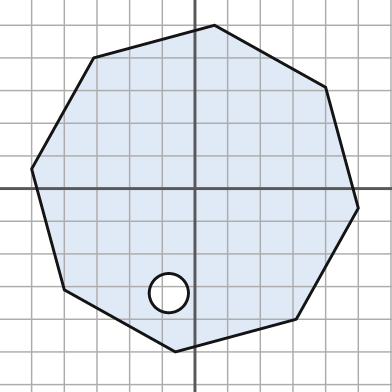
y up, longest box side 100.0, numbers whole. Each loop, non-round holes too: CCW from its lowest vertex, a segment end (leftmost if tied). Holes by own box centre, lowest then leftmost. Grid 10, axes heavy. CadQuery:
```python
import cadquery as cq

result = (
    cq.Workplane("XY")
    .moveTo(-6.0, -50.0)
    .lineTo(31.0, -40.0)
    .lineTo(50.0, -6.0)
    .lineTo(40.0, 31.0)
    .lineTo(6.0, 50.0)
    .lineTo(-31.0, 40.0)
    .lineTo(-50.0, 6.0)
    .lineTo(-40.0, -31.0)
    .close()
    .moveTo(-8.0, -32.0)
    .circle(6.0)
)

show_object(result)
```